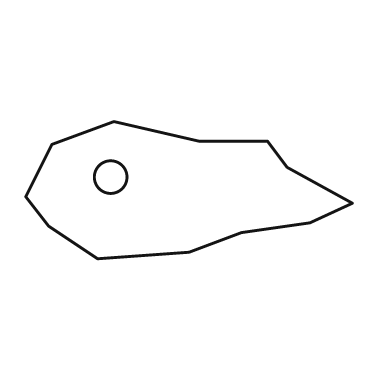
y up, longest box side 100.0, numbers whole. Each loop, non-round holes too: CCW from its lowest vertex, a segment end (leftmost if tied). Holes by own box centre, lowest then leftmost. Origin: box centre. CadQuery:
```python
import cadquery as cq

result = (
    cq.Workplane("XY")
    .moveTo(-28.0, -21.0)
    .lineTo(0.0, -19.0)
    .lineTo(16.0, -13.0)
    .lineTo(37.0, -10.0)
    .lineTo(50.0, -4.0)
    .lineTo(30.0, 7.0)
    .lineTo(24.0, 15.0)
    .lineTo(3.0, 15.0)
    .lineTo(-23.0, 21.0)
    .lineTo(-42.0, 14.0)
    .lineTo(-50.0, -2.0)
    .lineTo(-43.0, -11.0)
    .close()
    .moveTo(-24.0, 4.0)
    .circle(5.0)
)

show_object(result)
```